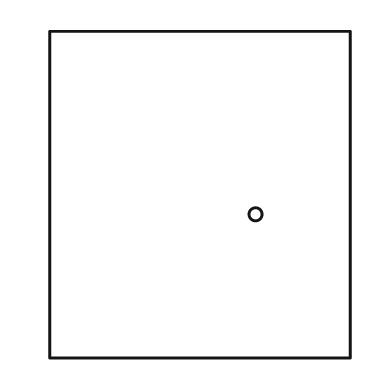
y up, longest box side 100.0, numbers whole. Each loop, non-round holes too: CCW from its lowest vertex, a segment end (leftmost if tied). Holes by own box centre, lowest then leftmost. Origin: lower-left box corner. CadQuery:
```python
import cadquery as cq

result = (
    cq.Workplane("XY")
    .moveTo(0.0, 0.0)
    .lineTo(92.0, 0.0)
    .lineTo(92.0, 100.0)
    .lineTo(0.0, 100.0)
    .close()
    .moveTo(63.0, 44.0)
    .circle(2.0)
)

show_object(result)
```